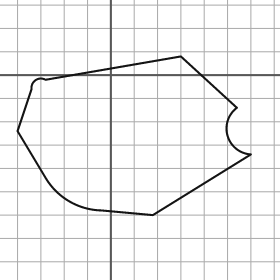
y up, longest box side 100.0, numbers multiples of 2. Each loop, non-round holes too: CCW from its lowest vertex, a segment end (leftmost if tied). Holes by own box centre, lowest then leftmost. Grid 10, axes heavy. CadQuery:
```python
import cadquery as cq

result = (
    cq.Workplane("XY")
    .moveTo(18.0, -60.0)
    .lineTo(60.0, -34.0)
    .threePointArc((50.0, -26.0), (54.0, -14.0))
    .lineTo(30.0, 8.0)
    .lineTo(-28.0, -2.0)
    .threePointArc((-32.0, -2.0), (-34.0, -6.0))
    .lineTo(-40.0, -24.0)
    .lineTo(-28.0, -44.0)
    .threePointArc((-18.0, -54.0), (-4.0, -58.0))
    .close()
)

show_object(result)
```